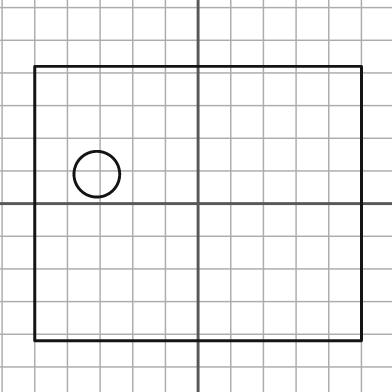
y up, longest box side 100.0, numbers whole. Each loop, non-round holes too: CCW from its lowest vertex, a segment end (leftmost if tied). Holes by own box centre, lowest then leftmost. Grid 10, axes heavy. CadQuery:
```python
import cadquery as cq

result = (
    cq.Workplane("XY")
    .moveTo(-50.0, -42.0)
    .lineTo(50.0, -42.0)
    .lineTo(50.0, 42.0)
    .lineTo(-50.0, 42.0)
    .close()
    .moveTo(-31.0, 9.0)
    .circle(7.0)
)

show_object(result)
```